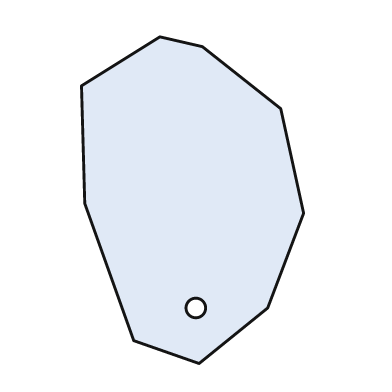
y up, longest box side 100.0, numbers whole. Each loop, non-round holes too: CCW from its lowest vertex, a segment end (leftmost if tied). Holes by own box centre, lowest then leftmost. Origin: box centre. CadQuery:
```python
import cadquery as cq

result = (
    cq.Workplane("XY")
    .moveTo(2.0, -50.0)
    .lineTo(23.0, -33.0)
    .lineTo(34.0, -4.0)
    .lineTo(27.0, 28.0)
    .lineTo(3.0, 47.0)
    .lineTo(-10.0, 50.0)
    .lineTo(-34.0, 35.0)
    .lineTo(-33.0, -1.0)
    .lineTo(-18.0, -43.0)
    .close()
    .moveTo(1.0, -33.0)
    .circle(3.0)
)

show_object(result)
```